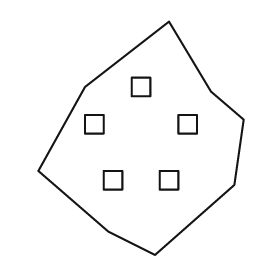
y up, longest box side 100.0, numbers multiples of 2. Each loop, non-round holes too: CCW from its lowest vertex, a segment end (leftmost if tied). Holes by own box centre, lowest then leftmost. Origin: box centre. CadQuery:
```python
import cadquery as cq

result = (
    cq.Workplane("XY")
    .moveTo(6.0, -50.0)
    .lineTo(40.0, -20.0)
    .lineTo(44.0, 8.0)
    .lineTo(30.0, 20.0)
    .lineTo(12.0, 50.0)
    .lineTo(-24.0, 22.0)
    .lineTo(-44.0, -14.0)
    .lineTo(-14.0, -40.0)
    .close()
    .moveTo(-16.0, -22.0)
    .lineTo(-8.0, -22.0)
    .lineTo(-8.0, -14.0)
    .lineTo(-16.0, -14.0)
    .close()
    .moveTo(8.0, -22.0)
    .lineTo(16.0, -22.0)
    .lineTo(16.0, -14.0)
    .lineTo(8.0, -14.0)
    .close()
    .moveTo(-24.0, 2.0)
    .lineTo(-16.0, 2.0)
    .lineTo(-16.0, 10.0)
    .lineTo(-24.0, 10.0)
    .close()
    .moveTo(16.0, 2.0)
    .lineTo(24.0, 2.0)
    .lineTo(24.0, 10.0)
    .lineTo(16.0, 10.0)
    .close()
    .moveTo(-4.0, 18.0)
    .lineTo(4.0, 18.0)
    .lineTo(4.0, 26.0)
    .lineTo(-4.0, 26.0)
    .close()
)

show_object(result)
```